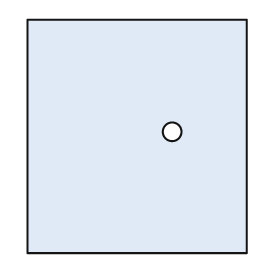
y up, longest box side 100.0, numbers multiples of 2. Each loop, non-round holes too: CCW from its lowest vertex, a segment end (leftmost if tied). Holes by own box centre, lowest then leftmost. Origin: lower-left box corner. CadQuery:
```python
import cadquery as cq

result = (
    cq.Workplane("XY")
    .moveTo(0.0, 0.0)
    .lineTo(94.0, 0.0)
    .lineTo(94.0, 100.0)
    .lineTo(0.0, 100.0)
    .close()
    .moveTo(62.0, 52.0)
    .circle(4.0)
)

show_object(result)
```